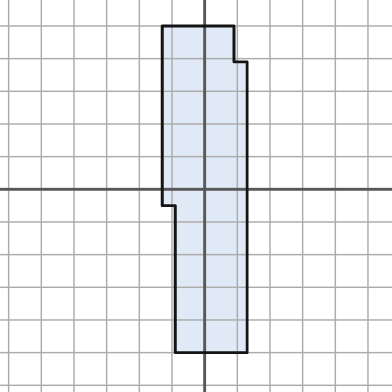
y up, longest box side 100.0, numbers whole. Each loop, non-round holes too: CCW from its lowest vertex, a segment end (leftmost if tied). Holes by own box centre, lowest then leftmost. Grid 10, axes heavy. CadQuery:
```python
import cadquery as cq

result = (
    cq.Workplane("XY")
    .moveTo(-9.0, -50.0)
    .lineTo(13.0, -50.0)
    .lineTo(13.0, 39.0)
    .lineTo(9.0, 39.0)
    .lineTo(9.0, 50.0)
    .lineTo(-13.0, 50.0)
    .lineTo(-13.0, -5.0)
    .lineTo(-9.0, -5.0)
    .close()
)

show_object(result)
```